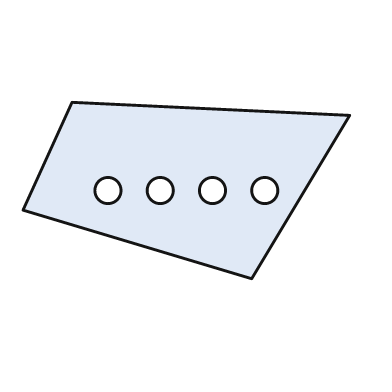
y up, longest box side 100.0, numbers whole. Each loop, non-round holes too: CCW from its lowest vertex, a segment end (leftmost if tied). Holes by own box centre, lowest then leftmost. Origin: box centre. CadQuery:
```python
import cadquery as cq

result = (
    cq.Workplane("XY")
    .moveTo(20.0, -27.0)
    .lineTo(50.0, 23.0)
    .lineTo(-35.0, 27.0)
    .lineTo(-50.0, -6.0)
    .close()
    .moveTo(-24.0, 0.0)
    .circle(4.0)
    .moveTo(-8.0, 0.0)
    .circle(4.0)
    .moveTo(8.0, 0.0)
    .circle(4.0)
    .moveTo(24.0, 0.0)
    .circle(4.0)
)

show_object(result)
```